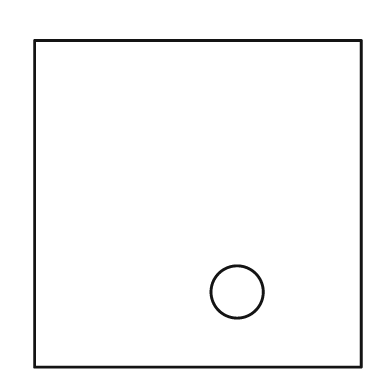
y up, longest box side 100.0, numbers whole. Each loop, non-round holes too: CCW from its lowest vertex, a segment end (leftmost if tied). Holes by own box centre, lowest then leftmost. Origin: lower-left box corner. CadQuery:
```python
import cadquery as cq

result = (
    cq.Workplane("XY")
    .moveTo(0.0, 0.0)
    .lineTo(100.0, 0.0)
    .lineTo(100.0, 100.0)
    .lineTo(0.0, 100.0)
    .close()
    .moveTo(62.0, 23.0)
    .circle(8.0)
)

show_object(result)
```